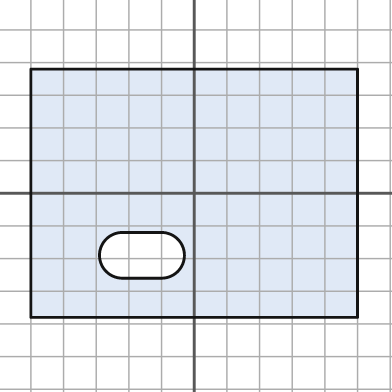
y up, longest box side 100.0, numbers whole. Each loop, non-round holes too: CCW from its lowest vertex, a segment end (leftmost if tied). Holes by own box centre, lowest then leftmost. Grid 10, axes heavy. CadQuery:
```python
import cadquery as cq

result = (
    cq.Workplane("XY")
    .moveTo(-50.0, -38.0)
    .lineTo(50.0, -38.0)
    .lineTo(50.0, 38.0)
    .lineTo(-50.0, 38.0)
    .close()
    .moveTo(-22.0, -26.0)
    .lineTo(-10.0, -26.0)
    .threePointArc((-3.0, -19.0), (-10.0, -12.0))
    .lineTo(-22.0, -12.0)
    .threePointArc((-29.0, -19.0), (-22.0, -26.0))
    .close()
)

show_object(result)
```